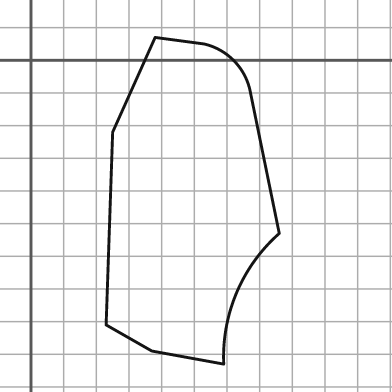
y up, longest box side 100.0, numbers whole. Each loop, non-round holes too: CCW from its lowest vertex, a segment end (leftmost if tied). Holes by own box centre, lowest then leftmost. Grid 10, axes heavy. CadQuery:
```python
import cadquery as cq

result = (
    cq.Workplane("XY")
    .moveTo(59.0, -93.0)
    .threePointArc((63.0, -71.0), (76.0, -53.0))
    .lineTo(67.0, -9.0)
    .threePointArc((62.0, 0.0), (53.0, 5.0))
    .lineTo(38.0, 7.0)
    .lineTo(25.0, -22.0)
    .lineTo(23.0, -81.0)
    .lineTo(37.0, -89.0)
    .close()
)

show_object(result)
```